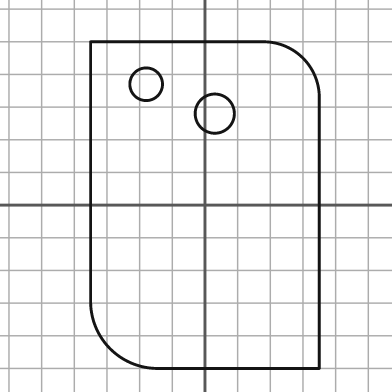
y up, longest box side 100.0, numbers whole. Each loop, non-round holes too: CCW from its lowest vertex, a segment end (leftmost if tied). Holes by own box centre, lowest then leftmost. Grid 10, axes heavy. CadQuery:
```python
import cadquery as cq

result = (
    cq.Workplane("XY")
    .moveTo(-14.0, -50.0)
    .lineTo(35.0, -50.0)
    .lineTo(35.0, 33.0)
    .threePointArc((30.0, 45.0), (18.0, 50.0))
    .lineTo(-35.0, 50.0)
    .lineTo(-35.0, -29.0)
    .threePointArc((-29.0, -44.0), (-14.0, -50.0))
    .close()
    .moveTo(3.0, 28.0)
    .circle(6.0)
    .moveTo(-18.0, 37.0)
    .circle(5.0)
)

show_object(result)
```